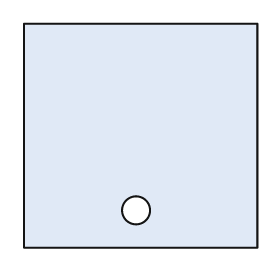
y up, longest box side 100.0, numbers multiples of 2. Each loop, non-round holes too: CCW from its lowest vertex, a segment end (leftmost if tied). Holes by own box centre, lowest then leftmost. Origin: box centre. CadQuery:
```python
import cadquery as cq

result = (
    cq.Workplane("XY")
    .moveTo(-50.0, -48.0)
    .lineTo(50.0, -48.0)
    .lineTo(50.0, 48.0)
    .lineTo(-50.0, 48.0)
    .close()
    .moveTo(-2.0, -32.0)
    .circle(6.0)
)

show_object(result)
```